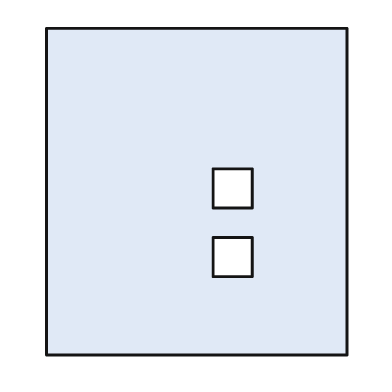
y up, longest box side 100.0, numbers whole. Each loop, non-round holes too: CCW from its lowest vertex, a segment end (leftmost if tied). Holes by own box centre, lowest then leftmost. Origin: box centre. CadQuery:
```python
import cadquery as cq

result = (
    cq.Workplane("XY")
    .moveTo(-46.0, -50.0)
    .lineTo(46.0, -50.0)
    .lineTo(46.0, 50.0)
    .lineTo(-46.0, 50.0)
    .close()
    .moveTo(5.0, -26.0)
    .lineTo(17.0, -26.0)
    .lineTo(17.0, -14.0)
    .lineTo(5.0, -14.0)
    .close()
    .moveTo(5.0, -5.0)
    .lineTo(17.0, -5.0)
    .lineTo(17.0, 7.0)
    .lineTo(5.0, 7.0)
    .close()
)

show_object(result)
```